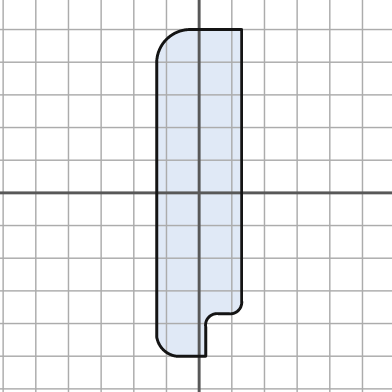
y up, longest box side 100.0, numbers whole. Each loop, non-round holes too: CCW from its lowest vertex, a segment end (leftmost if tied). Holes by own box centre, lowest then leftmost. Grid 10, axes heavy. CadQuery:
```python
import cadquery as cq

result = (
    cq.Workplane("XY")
    .moveTo(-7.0, -50.0)
    .lineTo(2.0, -50.0)
    .lineTo(2.0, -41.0)
    .threePointArc((3.0, -38.0), (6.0, -37.0))
    .lineTo(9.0, -37.0)
    .threePointArc((12.0, -36.0), (13.0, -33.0))
    .lineTo(13.0, 50.0)
    .lineTo(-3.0, 50.0)
    .threePointArc((-10.0, 47.0), (-13.0, 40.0))
    .lineTo(-13.0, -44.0)
    .threePointArc((-11.0, -48.0), (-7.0, -50.0))
    .close()
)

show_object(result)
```